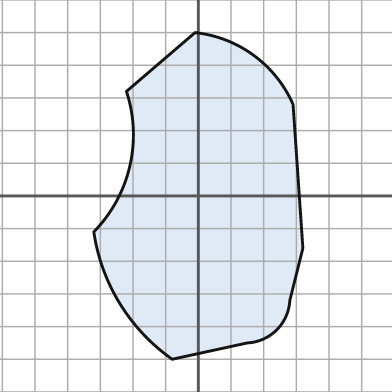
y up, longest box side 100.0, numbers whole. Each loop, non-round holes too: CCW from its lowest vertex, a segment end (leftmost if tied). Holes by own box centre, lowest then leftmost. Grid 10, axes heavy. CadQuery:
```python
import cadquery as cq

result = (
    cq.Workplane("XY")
    .moveTo(-8.0, -50.0)
    .lineTo(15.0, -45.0)
    .threePointArc((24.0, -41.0), (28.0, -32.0))
    .lineTo(32.0, -16.0)
    .lineTo(29.0, 28.0)
    .threePointArc((17.0, 43.0), (-1.0, 50.0))
    .lineTo(-22.0, 32.0)
    .threePointArc((-21.0, 9.0), (-32.0, -11.0))
    .threePointArc((-24.0, -33.0), (-8.0, -50.0))
    .close()
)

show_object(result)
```